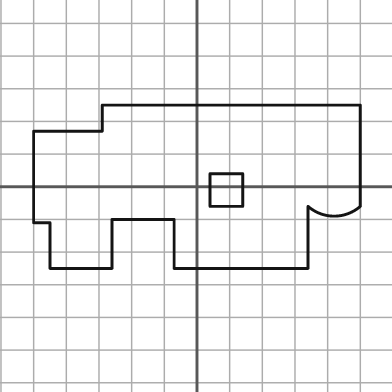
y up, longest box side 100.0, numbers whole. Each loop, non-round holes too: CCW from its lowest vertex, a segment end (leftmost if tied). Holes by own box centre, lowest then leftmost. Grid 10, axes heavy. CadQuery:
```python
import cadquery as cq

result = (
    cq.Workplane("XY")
    .moveTo(-45.0, -25.0)
    .lineTo(-26.0, -25.0)
    .lineTo(-26.0, -10.0)
    .lineTo(-7.0, -10.0)
    .lineTo(-7.0, -25.0)
    .lineTo(34.0, -25.0)
    .lineTo(34.0, -6.0)
    .threePointArc((42.0, -9.0), (50.0, -6.0))
    .lineTo(50.0, 25.0)
    .lineTo(-29.0, 25.0)
    .lineTo(-29.0, 17.0)
    .lineTo(-50.0, 17.0)
    .lineTo(-50.0, -11.0)
    .lineTo(-45.0, -11.0)
    .close()
    .moveTo(4.0, -6.0)
    .lineTo(14.0, -6.0)
    .lineTo(14.0, 4.0)
    .lineTo(4.0, 4.0)
    .close()
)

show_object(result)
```